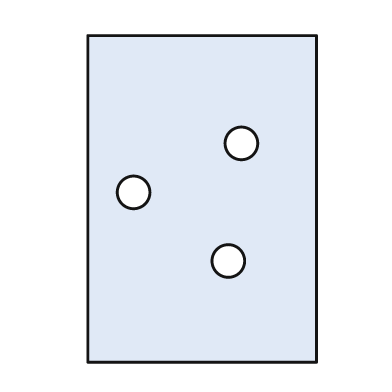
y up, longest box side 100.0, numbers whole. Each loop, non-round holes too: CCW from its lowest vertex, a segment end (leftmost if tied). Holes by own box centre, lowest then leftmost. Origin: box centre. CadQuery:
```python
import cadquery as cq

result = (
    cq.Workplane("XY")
    .moveTo(-35.0, -50.0)
    .lineTo(35.0, -50.0)
    .lineTo(35.0, 50.0)
    .lineTo(-35.0, 50.0)
    .close()
    .moveTo(8.0, -19.0)
    .circle(5.0)
    .moveTo(-21.0, 2.0)
    .circle(5.0)
    .moveTo(12.0, 17.0)
    .circle(5.0)
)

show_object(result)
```